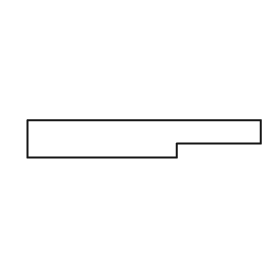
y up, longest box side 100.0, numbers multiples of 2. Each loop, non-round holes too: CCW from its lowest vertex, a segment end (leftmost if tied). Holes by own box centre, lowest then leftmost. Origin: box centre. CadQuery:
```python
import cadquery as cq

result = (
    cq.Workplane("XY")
    .moveTo(-50.0, -8.0)
    .lineTo(14.0, -8.0)
    .lineTo(14.0, -2.0)
    .lineTo(50.0, -2.0)
    .lineTo(50.0, 8.0)
    .lineTo(-50.0, 8.0)
    .close()
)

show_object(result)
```